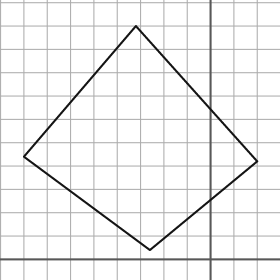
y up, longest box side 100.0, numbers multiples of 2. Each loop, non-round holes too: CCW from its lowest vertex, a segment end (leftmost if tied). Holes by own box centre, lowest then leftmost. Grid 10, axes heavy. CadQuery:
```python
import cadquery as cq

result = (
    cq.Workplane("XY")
    .moveTo(-26.0, 4.0)
    .lineTo(20.0, 42.0)
    .lineTo(-32.0, 100.0)
    .lineTo(-80.0, 44.0)
    .close()
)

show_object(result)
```